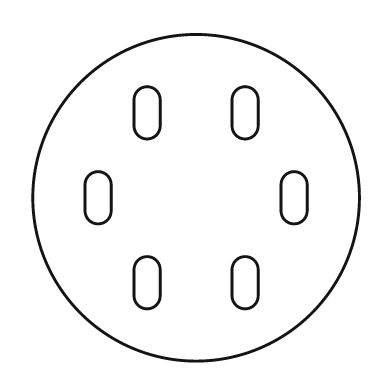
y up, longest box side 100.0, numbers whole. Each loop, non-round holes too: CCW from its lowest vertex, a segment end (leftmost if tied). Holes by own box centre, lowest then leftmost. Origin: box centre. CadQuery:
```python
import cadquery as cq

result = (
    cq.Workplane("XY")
    .moveTo(0.0, 0.0)
    .circle(50.0)
    .moveTo(-19.0, -30.0)
    .threePointArc((-15.0, -34.0), (-11.0, -30.0))
    .lineTo(-11.0, -22.0)
    .threePointArc((-15.0, -18.0), (-19.0, -22.0))
    .close()
    .moveTo(11.0, -30.0)
    .threePointArc((15.0, -34.0), (19.0, -30.0))
    .lineTo(19.0, -22.0)
    .threePointArc((15.0, -18.0), (11.0, -22.0))
    .close()
    .moveTo(-34.0, -4.0)
    .threePointArc((-30.0, -8.0), (-26.0, -4.0))
    .lineTo(-26.0, 4.0)
    .threePointArc((-30.0, 8.0), (-34.0, 4.0))
    .close()
    .moveTo(26.0, -4.0)
    .threePointArc((30.0, -8.0), (34.0, -4.0))
    .lineTo(34.0, 4.0)
    .threePointArc((30.0, 8.0), (26.0, 4.0))
    .close()
    .moveTo(-19.0, 22.0)
    .threePointArc((-15.0, 18.0), (-11.0, 22.0))
    .lineTo(-11.0, 30.0)
    .threePointArc((-15.0, 34.0), (-19.0, 30.0))
    .close()
    .moveTo(11.0, 22.0)
    .threePointArc((15.0, 18.0), (19.0, 22.0))
    .lineTo(19.0, 30.0)
    .threePointArc((15.0, 34.0), (11.0, 30.0))
    .close()
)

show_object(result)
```